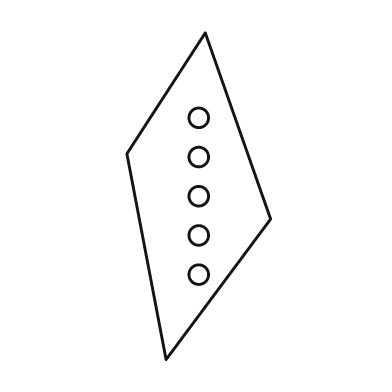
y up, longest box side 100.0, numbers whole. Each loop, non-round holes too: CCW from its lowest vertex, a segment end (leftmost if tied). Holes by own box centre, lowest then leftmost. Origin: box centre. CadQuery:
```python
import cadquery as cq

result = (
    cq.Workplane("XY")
    .moveTo(-10.0, -50.0)
    .lineTo(22.0, -7.0)
    .lineTo(2.0, 50.0)
    .lineTo(-22.0, 13.0)
    .close()
    .moveTo(0.0, -24.0)
    .circle(3.0)
    .moveTo(0.0, -12.0)
    .circle(3.0)
    .moveTo(0.0, 0.0)
    .circle(3.0)
    .moveTo(0.0, 12.0)
    .circle(3.0)
    .moveTo(0.0, 24.0)
    .circle(3.0)
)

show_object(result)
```